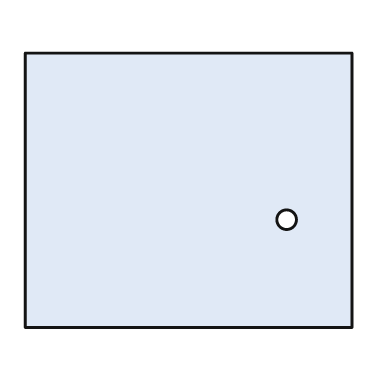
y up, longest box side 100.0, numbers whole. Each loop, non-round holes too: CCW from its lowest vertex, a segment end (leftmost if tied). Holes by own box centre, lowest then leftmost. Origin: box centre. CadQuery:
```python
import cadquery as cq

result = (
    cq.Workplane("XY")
    .moveTo(-50.0, -42.0)
    .lineTo(50.0, -42.0)
    .lineTo(50.0, 42.0)
    .lineTo(-50.0, 42.0)
    .close()
    .moveTo(30.0, -9.0)
    .circle(3.0)
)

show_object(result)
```